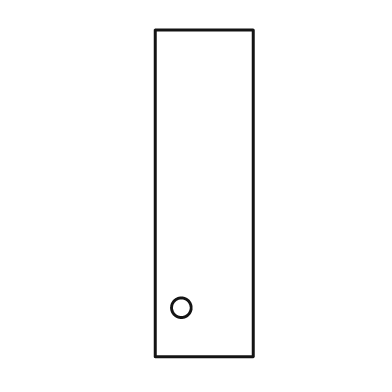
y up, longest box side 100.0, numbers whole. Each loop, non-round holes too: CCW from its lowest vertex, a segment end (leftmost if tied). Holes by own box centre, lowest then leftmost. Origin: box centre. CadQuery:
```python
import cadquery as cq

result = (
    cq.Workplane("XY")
    .moveTo(-15.0, -50.0)
    .lineTo(15.0, -50.0)
    .lineTo(15.0, 50.0)
    .lineTo(-15.0, 50.0)
    .close()
    .moveTo(-7.0, -35.0)
    .circle(3.0)
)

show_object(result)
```